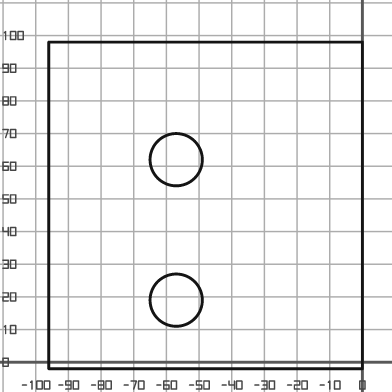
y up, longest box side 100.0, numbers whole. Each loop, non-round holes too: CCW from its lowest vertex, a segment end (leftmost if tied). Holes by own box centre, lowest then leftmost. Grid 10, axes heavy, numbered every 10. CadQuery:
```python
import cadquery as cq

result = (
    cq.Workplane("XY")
    .moveTo(-96.0, -2.0)
    .lineTo(0.0, -2.0)
    .lineTo(0.0, 98.0)
    .lineTo(-96.0, 98.0)
    .close()
    .moveTo(-57.0, 19.0)
    .circle(8.0)
    .moveTo(-57.0, 62.0)
    .circle(8.0)
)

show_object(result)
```